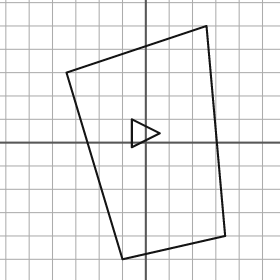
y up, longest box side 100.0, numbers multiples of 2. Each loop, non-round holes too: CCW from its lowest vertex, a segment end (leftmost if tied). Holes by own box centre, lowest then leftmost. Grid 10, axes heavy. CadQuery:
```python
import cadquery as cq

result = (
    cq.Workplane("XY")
    .moveTo(-10.0, -50.0)
    .lineTo(34.0, -40.0)
    .lineTo(26.0, 50.0)
    .lineTo(-34.0, 30.0)
    .close()
    .moveTo(-6.0, -2.0)
    .lineTo(6.0, 4.0)
    .lineTo(-6.0, 10.0)
    .close()
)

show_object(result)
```